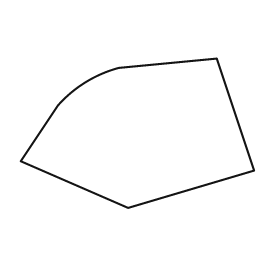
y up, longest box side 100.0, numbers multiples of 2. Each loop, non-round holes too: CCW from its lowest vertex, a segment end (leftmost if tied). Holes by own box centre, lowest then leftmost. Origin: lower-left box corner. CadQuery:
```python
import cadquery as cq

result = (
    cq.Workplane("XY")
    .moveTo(46.0, 0.0)
    .lineTo(100.0, 16.0)
    .lineTo(84.0, 64.0)
    .lineTo(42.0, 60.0)
    .threePointArc((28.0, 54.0), (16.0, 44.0))
    .lineTo(0.0, 20.0)
    .close()
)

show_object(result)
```